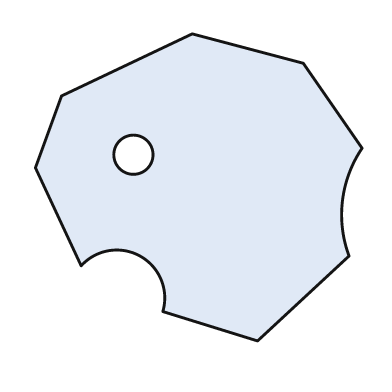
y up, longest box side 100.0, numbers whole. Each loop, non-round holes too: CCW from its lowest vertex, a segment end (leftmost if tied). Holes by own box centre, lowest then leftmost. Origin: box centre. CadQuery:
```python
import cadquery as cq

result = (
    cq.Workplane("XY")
    .moveTo(18.0, -47.0)
    .lineTo(46.0, -21.0)
    .threePointArc((44.0, -4.0), (50.0, 12.0))
    .lineTo(32.0, 38.0)
    .lineTo(-2.0, 47.0)
    .lineTo(-42.0, 28.0)
    .lineTo(-50.0, 6.0)
    .lineTo(-36.0, -24.0)
    .threePointArc((-18.0, -21.0), (-11.0, -38.0))
    .close()
    .moveTo(-20.0, 10.0)
    .circle(6.0)
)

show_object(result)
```